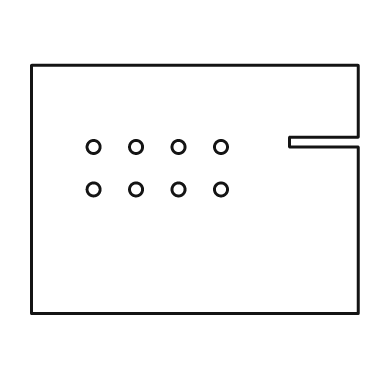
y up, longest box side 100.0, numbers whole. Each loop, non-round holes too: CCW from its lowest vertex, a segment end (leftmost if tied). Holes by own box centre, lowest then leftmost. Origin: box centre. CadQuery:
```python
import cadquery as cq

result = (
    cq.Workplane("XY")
    .moveTo(-50.0, -38.0)
    .lineTo(50.0, -38.0)
    .lineTo(50.0, 13.0)
    .lineTo(29.0, 13.0)
    .lineTo(29.0, 16.0)
    .lineTo(50.0, 16.0)
    .lineTo(50.0, 38.0)
    .lineTo(-50.0, 38.0)
    .close()
    .moveTo(-31.0, 0.0)
    .circle(2.0)
    .moveTo(-18.0, 0.0)
    .circle(2.0)
    .moveTo(-5.0, 0.0)
    .circle(2.0)
    .moveTo(8.0, 0.0)
    .circle(2.0)
    .moveTo(-31.0, 13.0)
    .circle(2.0)
    .moveTo(-18.0, 13.0)
    .circle(2.0)
    .moveTo(-5.0, 13.0)
    .circle(2.0)
    .moveTo(8.0, 13.0)
    .circle(2.0)
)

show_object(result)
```